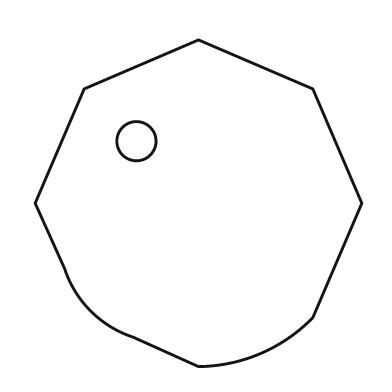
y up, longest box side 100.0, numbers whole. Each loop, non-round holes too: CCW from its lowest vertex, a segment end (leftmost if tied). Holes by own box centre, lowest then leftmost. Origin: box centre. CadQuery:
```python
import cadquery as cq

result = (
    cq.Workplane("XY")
    .moveTo(0.0, -50.0)
    .threePointArc((19.0, -46.0), (35.0, -35.0))
    .lineTo(50.0, 0.0)
    .lineTo(35.0, 35.0)
    .lineTo(0.0, 50.0)
    .lineTo(-35.0, 35.0)
    .lineTo(-50.0, 0.0)
    .lineTo(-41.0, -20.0)
    .threePointArc((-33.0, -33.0), (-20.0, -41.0))
    .close()
    .moveTo(-19.0, 19.0)
    .circle(6.0)
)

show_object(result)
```